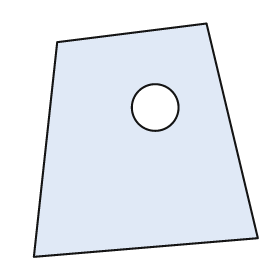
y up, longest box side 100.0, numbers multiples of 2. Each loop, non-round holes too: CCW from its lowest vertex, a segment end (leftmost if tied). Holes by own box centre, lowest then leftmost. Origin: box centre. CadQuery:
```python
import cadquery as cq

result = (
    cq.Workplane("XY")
    .moveTo(-48.0, -50.0)
    .lineTo(48.0, -42.0)
    .lineTo(26.0, 50.0)
    .lineTo(-38.0, 42.0)
    .close()
    .moveTo(4.0, 14.0)
    .circle(10.0)
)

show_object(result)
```